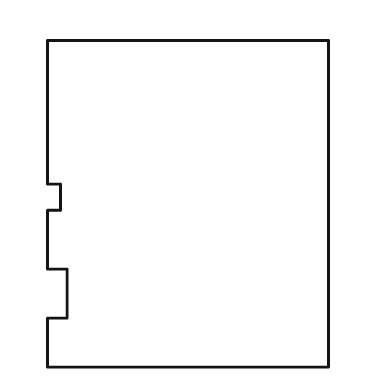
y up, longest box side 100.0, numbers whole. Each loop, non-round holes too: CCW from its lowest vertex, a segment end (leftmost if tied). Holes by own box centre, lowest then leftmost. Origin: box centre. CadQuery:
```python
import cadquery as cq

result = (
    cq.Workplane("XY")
    .moveTo(-43.0, -50.0)
    .lineTo(43.0, -50.0)
    .lineTo(43.0, 50.0)
    .lineTo(-43.0, 50.0)
    .lineTo(-43.0, 6.0)
    .lineTo(-39.0, 6.0)
    .lineTo(-39.0, -2.0)
    .lineTo(-43.0, -2.0)
    .lineTo(-43.0, -20.0)
    .lineTo(-37.0, -20.0)
    .lineTo(-37.0, -35.0)
    .lineTo(-43.0, -35.0)
    .close()
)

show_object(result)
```